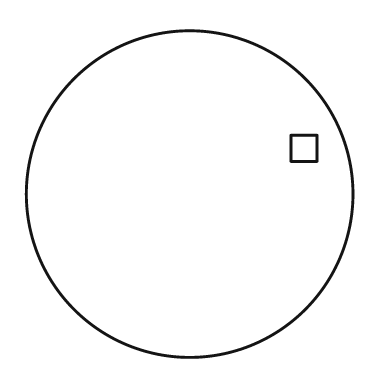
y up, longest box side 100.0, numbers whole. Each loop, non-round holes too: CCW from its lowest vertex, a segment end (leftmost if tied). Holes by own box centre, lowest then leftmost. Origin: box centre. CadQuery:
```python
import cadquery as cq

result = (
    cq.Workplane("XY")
    .moveTo(0.0, 0.0)
    .circle(50.0)
    .moveTo(31.0, 10.0)
    .lineTo(39.0, 10.0)
    .lineTo(39.0, 18.0)
    .lineTo(31.0, 18.0)
    .close()
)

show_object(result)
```